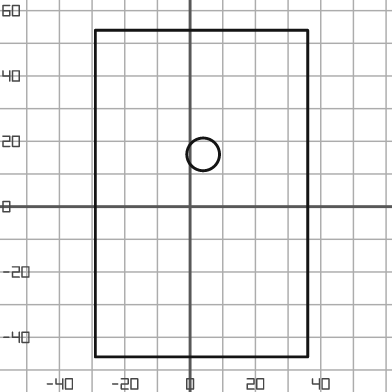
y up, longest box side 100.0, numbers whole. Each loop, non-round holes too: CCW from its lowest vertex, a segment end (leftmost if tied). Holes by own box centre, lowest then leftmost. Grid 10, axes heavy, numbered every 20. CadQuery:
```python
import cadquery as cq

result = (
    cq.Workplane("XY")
    .moveTo(-29.0, -46.0)
    .lineTo(36.0, -46.0)
    .lineTo(36.0, 54.0)
    .lineTo(-29.0, 54.0)
    .close()
    .moveTo(4.0, 16.0)
    .circle(5.0)
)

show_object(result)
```